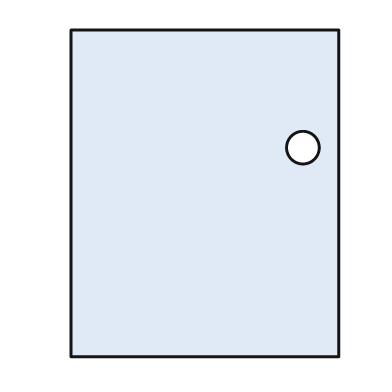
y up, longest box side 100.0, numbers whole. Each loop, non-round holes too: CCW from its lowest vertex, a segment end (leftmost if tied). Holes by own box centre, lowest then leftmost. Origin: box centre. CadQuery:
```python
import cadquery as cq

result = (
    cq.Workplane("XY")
    .moveTo(-41.0, -50.0)
    .lineTo(41.0, -50.0)
    .lineTo(41.0, 50.0)
    .lineTo(-41.0, 50.0)
    .close()
    .moveTo(30.0, 14.0)
    .circle(5.0)
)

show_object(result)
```